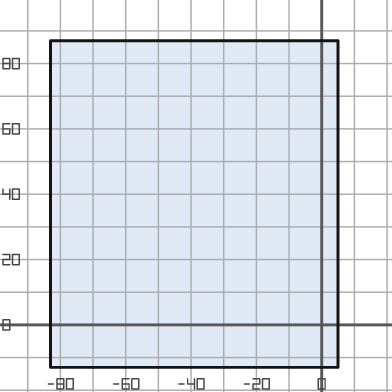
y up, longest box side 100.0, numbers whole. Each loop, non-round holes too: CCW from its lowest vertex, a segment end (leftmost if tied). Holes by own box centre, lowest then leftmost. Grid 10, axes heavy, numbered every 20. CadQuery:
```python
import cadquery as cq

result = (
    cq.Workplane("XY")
    .moveTo(-83.0, -13.0)
    .lineTo(5.0, -13.0)
    .lineTo(5.0, 87.0)
    .lineTo(-83.0, 87.0)
    .close()
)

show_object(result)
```